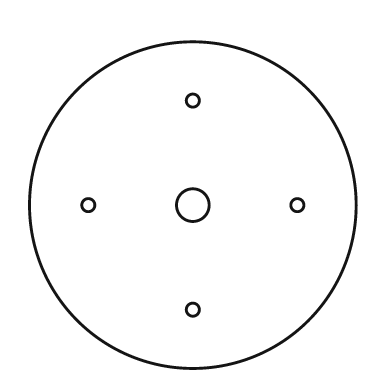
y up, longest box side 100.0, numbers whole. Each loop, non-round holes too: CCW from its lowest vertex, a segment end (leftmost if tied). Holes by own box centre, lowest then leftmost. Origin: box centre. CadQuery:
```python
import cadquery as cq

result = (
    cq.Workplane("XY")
    .moveTo(0.0, 0.0)
    .circle(50.0)
    .moveTo(0.0, -32.0)
    .circle(2.0)
    .moveTo(-32.0, 0.0)
    .circle(2.0)
    .moveTo(0.0, 0.0)
    .circle(5.0)
    .moveTo(32.0, 0.0)
    .circle(2.0)
    .moveTo(0.0, 32.0)
    .circle(2.0)
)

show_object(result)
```